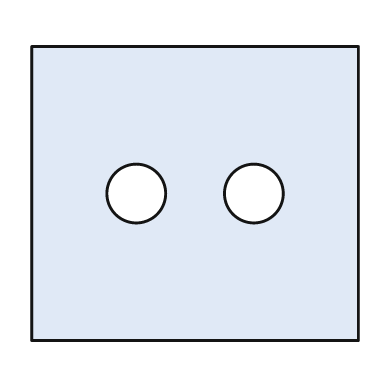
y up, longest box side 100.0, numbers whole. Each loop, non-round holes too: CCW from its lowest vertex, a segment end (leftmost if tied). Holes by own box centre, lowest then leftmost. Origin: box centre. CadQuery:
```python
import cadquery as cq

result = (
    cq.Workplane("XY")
    .moveTo(-50.0, -45.0)
    .lineTo(50.0, -45.0)
    .lineTo(50.0, 45.0)
    .lineTo(-50.0, 45.0)
    .close()
    .moveTo(-18.0, 0.0)
    .circle(9.0)
    .moveTo(18.0, 0.0)
    .circle(9.0)
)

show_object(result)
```